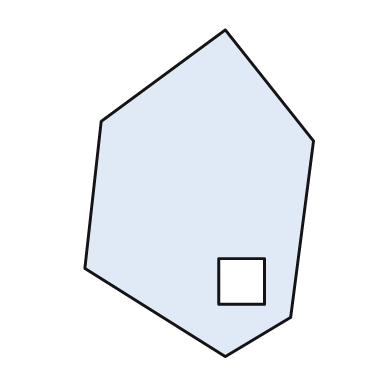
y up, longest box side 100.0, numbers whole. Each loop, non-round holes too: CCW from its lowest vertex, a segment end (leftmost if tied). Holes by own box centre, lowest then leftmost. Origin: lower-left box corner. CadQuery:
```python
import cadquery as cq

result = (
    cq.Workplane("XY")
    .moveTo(43.0, 0.0)
    .lineTo(63.0, 12.0)
    .lineTo(70.0, 66.0)
    .lineTo(43.0, 100.0)
    .lineTo(5.0, 72.0)
    .lineTo(0.0, 27.0)
    .close()
    .moveTo(41.0, 16.0)
    .lineTo(55.0, 16.0)
    .lineTo(55.0, 30.0)
    .lineTo(41.0, 30.0)
    .close()
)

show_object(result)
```